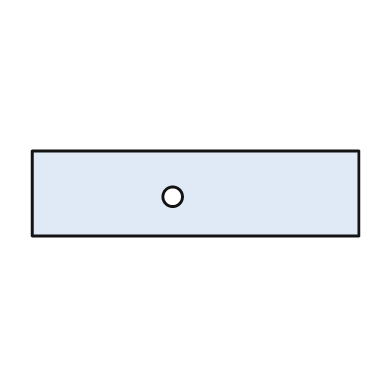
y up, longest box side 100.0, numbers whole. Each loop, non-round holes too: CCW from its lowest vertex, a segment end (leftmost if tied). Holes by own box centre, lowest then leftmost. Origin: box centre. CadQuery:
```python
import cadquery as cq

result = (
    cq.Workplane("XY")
    .moveTo(-50.0, -13.0)
    .lineTo(50.0, -13.0)
    .lineTo(50.0, 13.0)
    .lineTo(-50.0, 13.0)
    .close()
    .moveTo(-7.0, -1.0)
    .circle(3.0)
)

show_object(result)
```